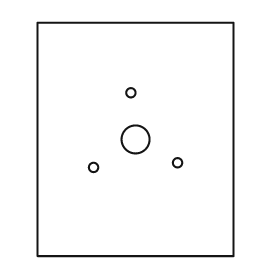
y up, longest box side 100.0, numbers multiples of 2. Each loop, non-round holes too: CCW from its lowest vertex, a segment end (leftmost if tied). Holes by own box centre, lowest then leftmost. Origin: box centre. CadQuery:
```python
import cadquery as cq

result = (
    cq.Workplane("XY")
    .moveTo(-42.0, -50.0)
    .lineTo(42.0, -50.0)
    .lineTo(42.0, 50.0)
    .lineTo(-42.0, 50.0)
    .close()
    .moveTo(-18.0, -12.0)
    .circle(2.0)
    .moveTo(18.0, -10.0)
    .circle(2.0)
    .moveTo(0.0, 0.0)
    .circle(6.0)
    .moveTo(-2.0, 20.0)
    .circle(2.0)
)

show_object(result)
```